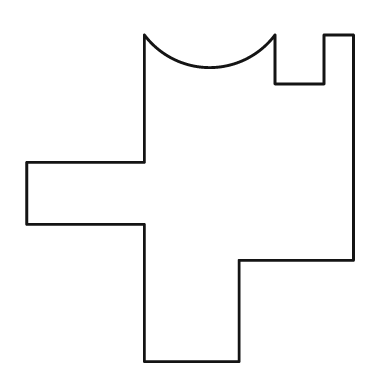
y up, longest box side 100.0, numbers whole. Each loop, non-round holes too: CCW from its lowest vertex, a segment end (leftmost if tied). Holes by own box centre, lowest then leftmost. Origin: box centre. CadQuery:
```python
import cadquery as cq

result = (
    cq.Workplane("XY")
    .moveTo(-14.0, -50.0)
    .lineTo(15.0, -50.0)
    .lineTo(15.0, -19.0)
    .lineTo(50.0, -19.0)
    .lineTo(50.0, 50.0)
    .lineTo(41.0, 50.0)
    .lineTo(41.0, 35.0)
    .lineTo(26.0, 35.0)
    .lineTo(26.0, 50.0)
    .threePointArc((6.0, 40.0), (-14.0, 50.0))
    .lineTo(-14.0, 11.0)
    .lineTo(-50.0, 11.0)
    .lineTo(-50.0, -8.0)
    .lineTo(-14.0, -8.0)
    .close()
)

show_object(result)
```